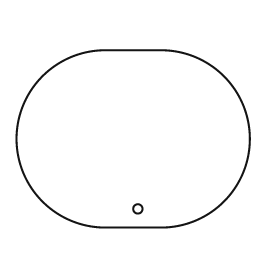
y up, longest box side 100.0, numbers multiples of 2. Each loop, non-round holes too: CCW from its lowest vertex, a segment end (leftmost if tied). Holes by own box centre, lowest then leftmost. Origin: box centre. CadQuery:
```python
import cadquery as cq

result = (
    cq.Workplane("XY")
    .moveTo(-12.0, -38.0)
    .lineTo(12.0, -38.0)
    .threePointArc((50.0, 0.0), (12.0, 38.0))
    .lineTo(-12.0, 38.0)
    .threePointArc((-50.0, 0.0), (-12.0, -38.0))
    .close()
    .moveTo(2.0, -30.0)
    .circle(2.0)
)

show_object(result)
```